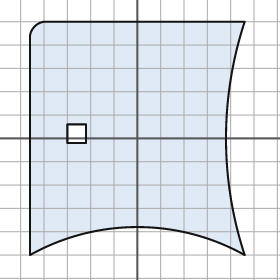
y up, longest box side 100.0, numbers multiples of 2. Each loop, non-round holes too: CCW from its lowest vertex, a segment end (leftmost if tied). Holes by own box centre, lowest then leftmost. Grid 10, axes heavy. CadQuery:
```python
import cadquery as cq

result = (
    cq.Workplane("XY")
    .moveTo(-46.0, -50.0)
    .threePointArc((0.0, -38.0), (46.0, -50.0))
    .threePointArc((38.0, 0.0), (46.0, 50.0))
    .lineTo(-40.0, 50.0)
    .threePointArc((-44.0, 48.0), (-46.0, 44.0))
    .close()
    .moveTo(-30.0, -2.0)
    .lineTo(-22.0, -2.0)
    .lineTo(-22.0, 6.0)
    .lineTo(-30.0, 6.0)
    .close()
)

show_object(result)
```